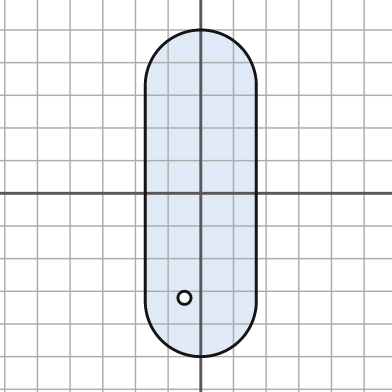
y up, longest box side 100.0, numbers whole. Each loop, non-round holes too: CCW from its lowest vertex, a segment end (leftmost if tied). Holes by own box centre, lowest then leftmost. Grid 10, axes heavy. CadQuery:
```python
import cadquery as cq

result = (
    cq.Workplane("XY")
    .moveTo(-17.0, -33.0)
    .threePointArc((0.0, -50.0), (17.0, -33.0))
    .lineTo(17.0, 33.0)
    .threePointArc((0.0, 50.0), (-17.0, 33.0))
    .close()
    .moveTo(-5.0, -32.0)
    .circle(2.0)
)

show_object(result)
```